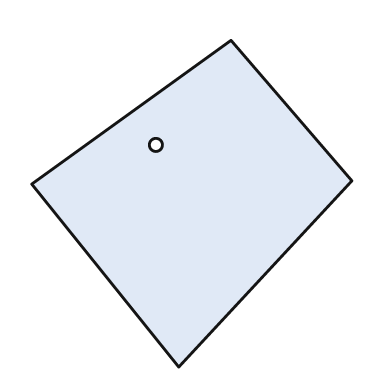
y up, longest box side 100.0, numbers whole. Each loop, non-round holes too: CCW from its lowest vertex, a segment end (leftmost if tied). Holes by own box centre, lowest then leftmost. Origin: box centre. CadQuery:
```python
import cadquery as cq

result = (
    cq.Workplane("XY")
    .moveTo(-4.0, -50.0)
    .lineTo(49.0, 7.0)
    .lineTo(12.0, 50.0)
    .lineTo(-49.0, 6.0)
    .close()
    .moveTo(-11.0, 18.0)
    .circle(2.0)
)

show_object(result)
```